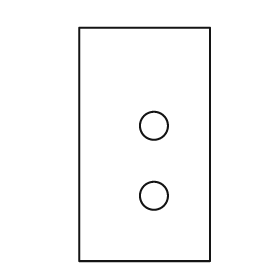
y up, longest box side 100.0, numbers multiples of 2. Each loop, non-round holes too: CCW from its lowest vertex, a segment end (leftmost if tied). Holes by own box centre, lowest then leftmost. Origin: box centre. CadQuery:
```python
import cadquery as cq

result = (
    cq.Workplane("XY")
    .moveTo(-28.0, -50.0)
    .lineTo(28.0, -50.0)
    .lineTo(28.0, 50.0)
    .lineTo(-28.0, 50.0)
    .close()
    .moveTo(4.0, -22.0)
    .circle(6.0)
    .moveTo(4.0, 8.0)
    .circle(6.0)
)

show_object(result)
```